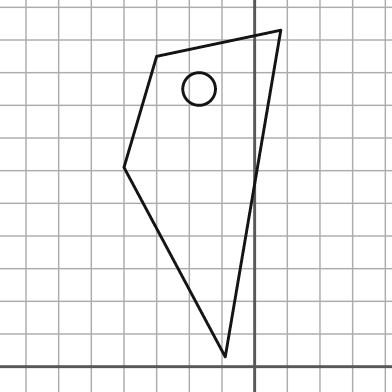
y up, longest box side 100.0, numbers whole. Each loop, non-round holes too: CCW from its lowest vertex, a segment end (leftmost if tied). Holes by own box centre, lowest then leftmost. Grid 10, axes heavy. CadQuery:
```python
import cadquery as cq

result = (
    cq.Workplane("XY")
    .moveTo(-9.0, 3.0)
    .lineTo(8.0, 103.0)
    .lineTo(-30.0, 95.0)
    .lineTo(-40.0, 61.0)
    .close()
    .moveTo(-17.0, 85.0)
    .circle(5.0)
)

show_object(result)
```